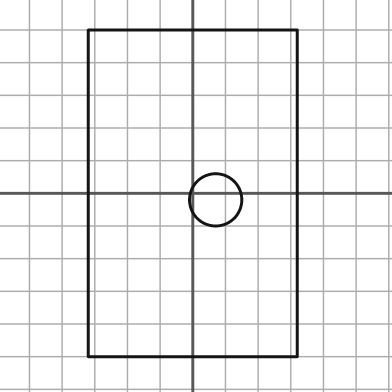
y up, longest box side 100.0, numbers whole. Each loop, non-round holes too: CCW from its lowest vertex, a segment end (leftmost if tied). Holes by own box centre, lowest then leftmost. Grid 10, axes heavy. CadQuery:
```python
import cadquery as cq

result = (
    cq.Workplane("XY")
    .moveTo(-32.0, -50.0)
    .lineTo(32.0, -50.0)
    .lineTo(32.0, 50.0)
    .lineTo(-32.0, 50.0)
    .close()
    .moveTo(7.0, -2.0)
    .circle(8.0)
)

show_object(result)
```